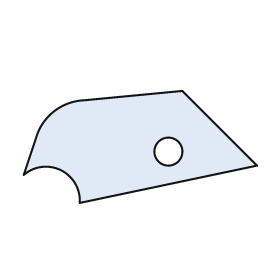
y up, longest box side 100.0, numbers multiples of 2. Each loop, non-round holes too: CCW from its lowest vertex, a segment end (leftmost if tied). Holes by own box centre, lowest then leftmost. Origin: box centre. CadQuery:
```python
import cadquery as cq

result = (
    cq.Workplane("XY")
    .moveTo(-26.0, -24.0)
    .lineTo(50.0, -8.0)
    .lineTo(18.0, 24.0)
    .lineTo(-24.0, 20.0)
    .threePointArc((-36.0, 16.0), (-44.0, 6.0))
    .lineTo(-50.0, -12.0)
    .threePointArc((-34.0, -10.0), (-26.0, -24.0))
    .close()
    .moveTo(12.0, -2.0)
    .circle(6.0)
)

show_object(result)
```